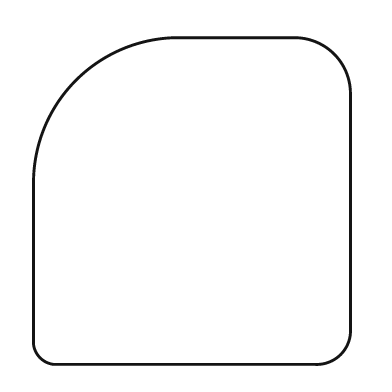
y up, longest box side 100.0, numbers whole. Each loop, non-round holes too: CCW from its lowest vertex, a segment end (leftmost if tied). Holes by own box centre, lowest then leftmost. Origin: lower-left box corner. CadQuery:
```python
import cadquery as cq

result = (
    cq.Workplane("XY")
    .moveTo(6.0, 0.0)
    .lineTo(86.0, 0.0)
    .threePointArc((94.0, 3.0), (97.0, 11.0))
    .lineTo(97.0, 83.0)
    .threePointArc((92.0, 95.0), (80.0, 100.0))
    .lineTo(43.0, 100.0)
    .threePointArc((13.0, 87.0), (0.0, 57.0))
    .lineTo(0.0, 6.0)
    .threePointArc((2.0, 2.0), (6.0, 0.0))
    .close()
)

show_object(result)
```